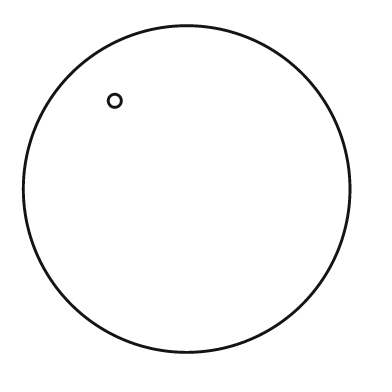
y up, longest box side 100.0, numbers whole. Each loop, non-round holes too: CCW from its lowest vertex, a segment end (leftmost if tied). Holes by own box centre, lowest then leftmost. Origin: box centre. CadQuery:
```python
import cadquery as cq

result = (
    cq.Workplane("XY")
    .moveTo(0.0, 0.0)
    .circle(50.0)
    .moveTo(-22.0, 27.0)
    .circle(2.0)
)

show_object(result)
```